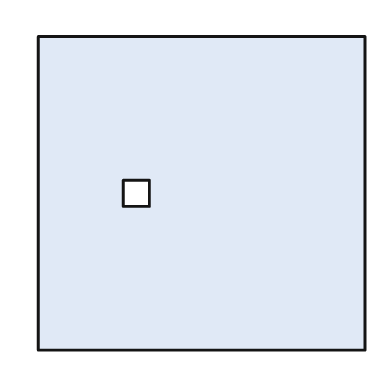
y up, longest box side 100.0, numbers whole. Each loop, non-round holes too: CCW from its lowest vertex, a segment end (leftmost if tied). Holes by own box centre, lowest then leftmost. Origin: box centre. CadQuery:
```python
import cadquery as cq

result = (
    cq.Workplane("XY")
    .moveTo(-50.0, -48.0)
    .lineTo(50.0, -48.0)
    .lineTo(50.0, 48.0)
    .lineTo(-50.0, 48.0)
    .close()
    .moveTo(-24.0, -4.0)
    .lineTo(-16.0, -4.0)
    .lineTo(-16.0, 4.0)
    .lineTo(-24.0, 4.0)
    .close()
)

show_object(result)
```